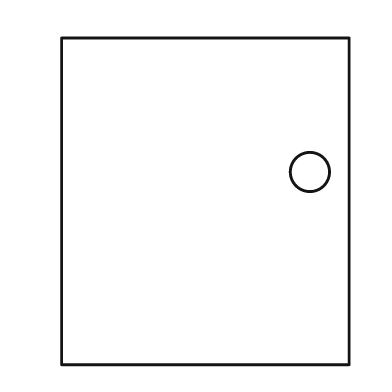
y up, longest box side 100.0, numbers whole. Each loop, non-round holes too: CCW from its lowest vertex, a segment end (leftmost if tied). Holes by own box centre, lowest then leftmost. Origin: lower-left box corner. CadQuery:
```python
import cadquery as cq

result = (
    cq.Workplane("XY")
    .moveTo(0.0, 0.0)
    .lineTo(88.0, 0.0)
    .lineTo(88.0, 100.0)
    .lineTo(0.0, 100.0)
    .close()
    .moveTo(76.0, 59.0)
    .circle(6.0)
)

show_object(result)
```